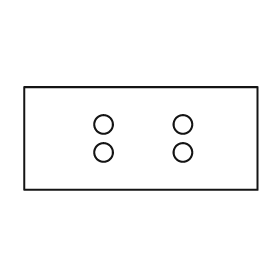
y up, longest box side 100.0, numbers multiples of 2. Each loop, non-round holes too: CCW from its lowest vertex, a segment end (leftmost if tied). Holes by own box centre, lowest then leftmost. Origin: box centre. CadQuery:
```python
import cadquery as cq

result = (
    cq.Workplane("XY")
    .moveTo(-50.0, -22.0)
    .lineTo(50.0, -22.0)
    .lineTo(50.0, 22.0)
    .lineTo(-50.0, 22.0)
    .close()
    .moveTo(-16.0, -6.0)
    .circle(4.0)
    .moveTo(18.0, -6.0)
    .circle(4.0)
    .moveTo(-16.0, 6.0)
    .circle(4.0)
    .moveTo(18.0, 6.0)
    .circle(4.0)
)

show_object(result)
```